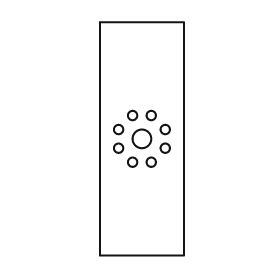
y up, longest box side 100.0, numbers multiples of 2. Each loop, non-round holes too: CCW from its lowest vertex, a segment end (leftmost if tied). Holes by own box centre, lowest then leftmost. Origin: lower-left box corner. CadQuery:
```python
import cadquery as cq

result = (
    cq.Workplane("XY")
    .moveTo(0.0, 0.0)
    .lineTo(36.0, 0.0)
    .lineTo(36.0, 100.0)
    .lineTo(0.0, 100.0)
    .close()
    .moveTo(14.0, 40.0)
    .circle(2.0)
    .moveTo(22.0, 40.0)
    .circle(2.0)
    .moveTo(8.0, 46.0)
    .circle(2.0)
    .moveTo(28.0, 46.0)
    .circle(2.0)
    .moveTo(18.0, 50.0)
    .circle(4.0)
    .moveTo(8.0, 54.0)
    .circle(2.0)
    .moveTo(28.0, 54.0)
    .circle(2.0)
    .moveTo(14.0, 60.0)
    .circle(2.0)
    .moveTo(22.0, 60.0)
    .circle(2.0)
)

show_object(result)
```